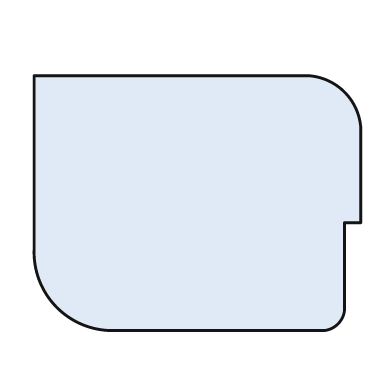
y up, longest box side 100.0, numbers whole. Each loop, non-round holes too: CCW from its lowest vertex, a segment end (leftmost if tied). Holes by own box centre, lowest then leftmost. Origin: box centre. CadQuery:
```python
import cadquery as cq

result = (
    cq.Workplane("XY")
    .moveTo(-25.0, -39.0)
    .lineTo(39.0, -39.0)
    .threePointArc((43.0, -37.0), (45.0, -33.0))
    .lineTo(45.0, -6.0)
    .lineTo(50.0, -6.0)
    .lineTo(50.0, 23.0)
    .threePointArc((45.0, 34.0), (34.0, 39.0))
    .lineTo(-50.0, 39.0)
    .lineTo(-50.0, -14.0)
    .threePointArc((-43.0, -32.0), (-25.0, -39.0))
    .close()
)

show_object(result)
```